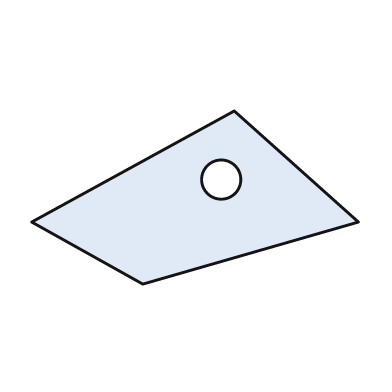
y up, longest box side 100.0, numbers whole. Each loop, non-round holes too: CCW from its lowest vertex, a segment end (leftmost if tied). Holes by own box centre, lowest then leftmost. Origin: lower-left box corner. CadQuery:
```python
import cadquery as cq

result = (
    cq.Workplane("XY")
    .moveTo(34.0, 0.0)
    .lineTo(100.0, 19.0)
    .lineTo(62.0, 53.0)
    .lineTo(0.0, 19.0)
    .close()
    .moveTo(58.0, 32.0)
    .circle(6.0)
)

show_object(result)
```